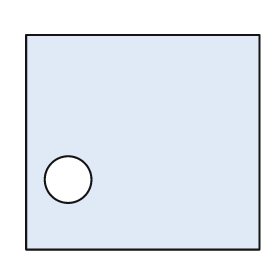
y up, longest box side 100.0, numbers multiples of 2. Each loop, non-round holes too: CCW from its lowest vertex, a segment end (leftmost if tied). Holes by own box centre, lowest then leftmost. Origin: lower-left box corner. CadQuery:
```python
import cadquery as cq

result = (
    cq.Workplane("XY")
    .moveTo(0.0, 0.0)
    .lineTo(100.0, 0.0)
    .lineTo(100.0, 92.0)
    .lineTo(0.0, 92.0)
    .close()
    .moveTo(18.0, 30.0)
    .circle(10.0)
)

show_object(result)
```